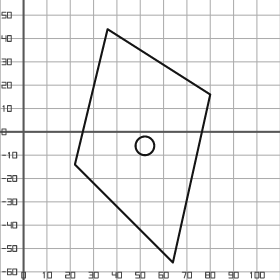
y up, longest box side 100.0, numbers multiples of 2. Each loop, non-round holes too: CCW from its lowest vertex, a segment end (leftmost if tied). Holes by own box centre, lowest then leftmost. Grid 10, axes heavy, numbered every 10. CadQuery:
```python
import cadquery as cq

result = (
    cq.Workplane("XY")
    .moveTo(64.0, -56.0)
    .lineTo(80.0, 16.0)
    .lineTo(36.0, 44.0)
    .lineTo(22.0, -14.0)
    .close()
    .moveTo(52.0, -6.0)
    .circle(4.0)
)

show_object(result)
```